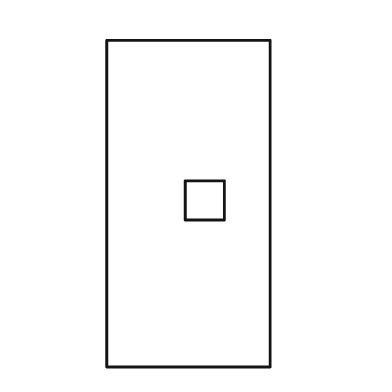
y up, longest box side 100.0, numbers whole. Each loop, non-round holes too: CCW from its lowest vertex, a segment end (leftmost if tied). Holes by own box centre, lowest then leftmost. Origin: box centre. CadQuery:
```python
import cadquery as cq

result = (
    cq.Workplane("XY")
    .moveTo(-25.0, -50.0)
    .lineTo(25.0, -50.0)
    .lineTo(25.0, 50.0)
    .lineTo(-25.0, 50.0)
    .close()
    .moveTo(-1.0, -5.0)
    .lineTo(11.0, -5.0)
    .lineTo(11.0, 7.0)
    .lineTo(-1.0, 7.0)
    .close()
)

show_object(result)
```